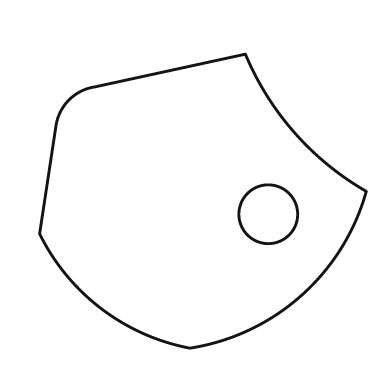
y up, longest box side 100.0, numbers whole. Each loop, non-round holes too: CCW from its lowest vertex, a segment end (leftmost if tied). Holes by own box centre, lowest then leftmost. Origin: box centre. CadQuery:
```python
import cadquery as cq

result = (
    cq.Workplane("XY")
    .moveTo(-4.0, -45.0)
    .threePointArc((30.0, -29.0), (50.0, 3.0))
    .threePointArc((28.0, 21.0), (13.0, 45.0))
    .lineTo(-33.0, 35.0)
    .threePointArc((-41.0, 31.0), (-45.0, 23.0))
    .lineTo(-50.0, -10.0)
    .threePointArc((-31.0, -33.0), (-4.0, -45.0))
    .close()
    .moveTo(20.0, -4.0)
    .circle(9.0)
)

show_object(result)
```